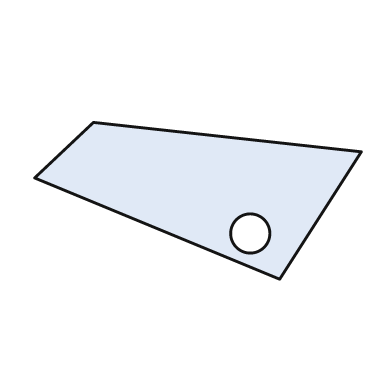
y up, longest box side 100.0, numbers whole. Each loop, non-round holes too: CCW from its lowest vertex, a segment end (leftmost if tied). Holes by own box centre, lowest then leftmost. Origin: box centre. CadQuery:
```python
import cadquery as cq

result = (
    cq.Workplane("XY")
    .moveTo(25.0, -24.0)
    .lineTo(50.0, 15.0)
    .lineTo(-32.0, 24.0)
    .lineTo(-50.0, 7.0)
    .close()
    .moveTo(16.0, -10.0)
    .circle(6.0)
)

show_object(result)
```